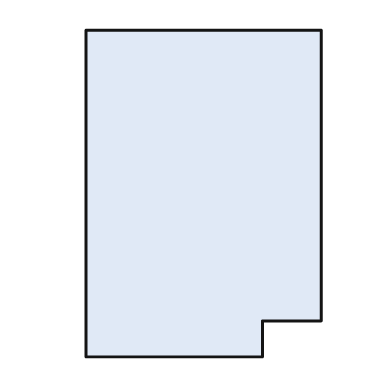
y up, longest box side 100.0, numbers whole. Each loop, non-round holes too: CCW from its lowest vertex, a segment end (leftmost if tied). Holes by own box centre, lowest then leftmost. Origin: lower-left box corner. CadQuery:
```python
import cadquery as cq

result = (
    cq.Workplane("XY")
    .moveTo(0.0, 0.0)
    .lineTo(54.0, 0.0)
    .lineTo(54.0, 11.0)
    .lineTo(72.0, 11.0)
    .lineTo(72.0, 100.0)
    .lineTo(0.0, 100.0)
    .close()
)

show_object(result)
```